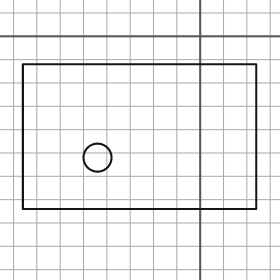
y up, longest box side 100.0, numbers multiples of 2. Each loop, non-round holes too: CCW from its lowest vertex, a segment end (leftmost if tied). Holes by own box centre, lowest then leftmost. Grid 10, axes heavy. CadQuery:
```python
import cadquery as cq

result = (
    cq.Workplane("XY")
    .moveTo(-76.0, -74.0)
    .lineTo(24.0, -74.0)
    .lineTo(24.0, -12.0)
    .lineTo(-76.0, -12.0)
    .close()
    .moveTo(-44.0, -52.0)
    .circle(6.0)
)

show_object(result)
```